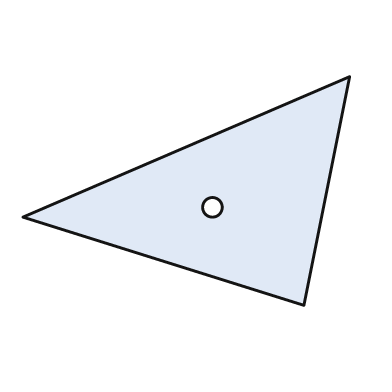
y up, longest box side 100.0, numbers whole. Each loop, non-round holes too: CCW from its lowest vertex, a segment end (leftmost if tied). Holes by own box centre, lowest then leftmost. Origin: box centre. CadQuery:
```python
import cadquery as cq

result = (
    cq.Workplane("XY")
    .moveTo(36.0, -35.0)
    .lineTo(50.0, 35.0)
    .lineTo(-50.0, -8.0)
    .close()
    .moveTo(8.0, -5.0)
    .circle(3.0)
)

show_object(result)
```